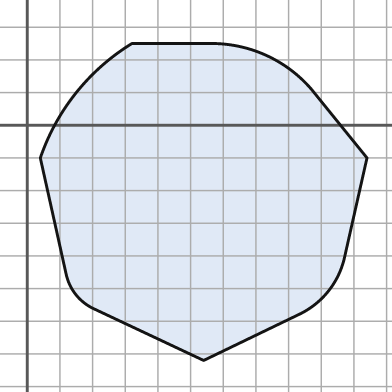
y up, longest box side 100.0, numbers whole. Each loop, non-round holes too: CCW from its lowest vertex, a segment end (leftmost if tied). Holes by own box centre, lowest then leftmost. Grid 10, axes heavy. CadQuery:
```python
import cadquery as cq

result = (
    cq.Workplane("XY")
    .moveTo(54.0, -72.0)
    .lineTo(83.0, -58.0)
    .threePointArc((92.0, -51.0), (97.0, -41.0))
    .lineTo(104.0, -10.0)
    .lineTo(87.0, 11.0)
    .threePointArc((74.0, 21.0), (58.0, 25.0))
    .lineTo(32.0, 25.0)
    .threePointArc((15.0, 10.0), (4.0, -10.0))
    .lineTo(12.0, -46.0)
    .threePointArc((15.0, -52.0), (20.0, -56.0))
    .close()
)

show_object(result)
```